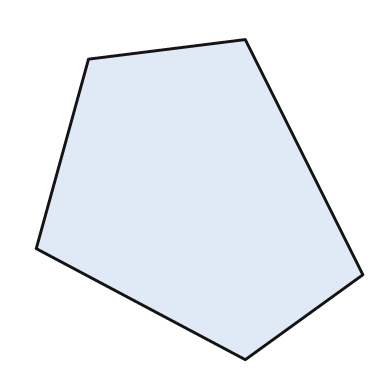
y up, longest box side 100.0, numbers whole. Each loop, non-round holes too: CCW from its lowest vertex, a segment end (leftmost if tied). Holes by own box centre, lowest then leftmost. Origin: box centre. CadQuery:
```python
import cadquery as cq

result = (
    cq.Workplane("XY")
    .moveTo(14.0, -49.0)
    .lineTo(50.0, -23.0)
    .lineTo(14.0, 49.0)
    .lineTo(-34.0, 43.0)
    .lineTo(-50.0, -15.0)
    .close()
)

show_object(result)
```